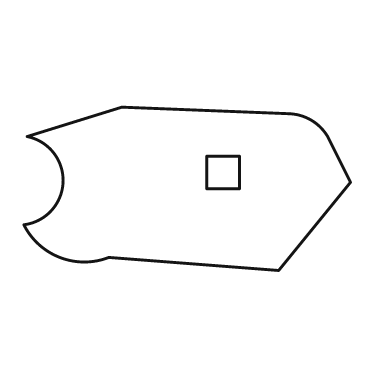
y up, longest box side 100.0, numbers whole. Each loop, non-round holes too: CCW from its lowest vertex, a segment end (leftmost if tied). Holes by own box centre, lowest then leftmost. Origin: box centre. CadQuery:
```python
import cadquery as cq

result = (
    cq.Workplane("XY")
    .moveTo(28.0, -25.0)
    .lineTo(50.0, 2.0)
    .lineTo(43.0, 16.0)
    .threePointArc((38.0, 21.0), (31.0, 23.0))
    .lineTo(-20.0, 25.0)
    .lineTo(-49.0, 16.0)
    .threePointArc((-38.0, 2.0), (-50.0, -11.0))
    .threePointArc((-39.0, -21.0), (-24.0, -21.0))
    .close()
    .moveTo(6.0, 0.0)
    .lineTo(16.0, 0.0)
    .lineTo(16.0, 10.0)
    .lineTo(6.0, 10.0)
    .close()
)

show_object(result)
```